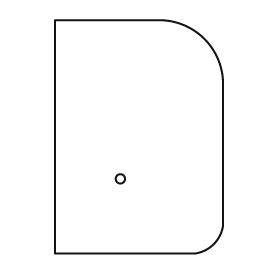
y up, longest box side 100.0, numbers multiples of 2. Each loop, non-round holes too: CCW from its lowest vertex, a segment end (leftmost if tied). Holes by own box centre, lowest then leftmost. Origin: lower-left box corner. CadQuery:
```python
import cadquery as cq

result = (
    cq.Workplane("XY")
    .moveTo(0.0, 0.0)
    .lineTo(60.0, 0.0)
    .threePointArc((68.0, 4.0), (72.0, 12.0))
    .lineTo(72.0, 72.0)
    .threePointArc((64.0, 92.0), (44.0, 100.0))
    .lineTo(0.0, 100.0)
    .close()
    .moveTo(28.0, 32.0)
    .circle(2.0)
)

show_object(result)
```